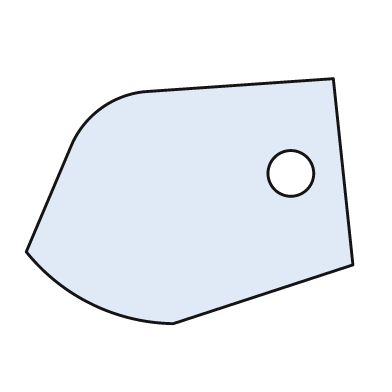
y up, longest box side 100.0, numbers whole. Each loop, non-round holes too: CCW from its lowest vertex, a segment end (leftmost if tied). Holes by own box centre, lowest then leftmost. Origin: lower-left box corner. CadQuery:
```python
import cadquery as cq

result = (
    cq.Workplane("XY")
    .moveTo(45.0, 0.0)
    .lineTo(100.0, 18.0)
    .lineTo(94.0, 75.0)
    .lineTo(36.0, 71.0)
    .threePointArc((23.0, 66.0), (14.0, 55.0))
    .lineTo(0.0, 22.0)
    .threePointArc((20.0, 6.0), (45.0, 0.0))
    .close()
    .moveTo(81.0, 46.0)
    .circle(7.0)
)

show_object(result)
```